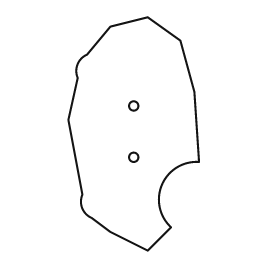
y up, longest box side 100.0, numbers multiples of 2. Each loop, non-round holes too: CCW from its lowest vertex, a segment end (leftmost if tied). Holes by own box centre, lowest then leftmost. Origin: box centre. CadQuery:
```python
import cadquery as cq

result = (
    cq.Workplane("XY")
    .moveTo(6.0, -50.0)
    .lineTo(16.0, -40.0)
    .threePointArc((12.0, -22.0), (28.0, -12.0))
    .lineTo(26.0, 18.0)
    .lineTo(20.0, 40.0)
    .lineTo(6.0, 50.0)
    .lineTo(-10.0, 46.0)
    .lineTo(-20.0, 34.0)
    .threePointArc((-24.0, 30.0), (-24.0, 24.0))
    .lineTo(-28.0, 6.0)
    .lineTo(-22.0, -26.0)
    .threePointArc((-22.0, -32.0), (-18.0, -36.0))
    .lineTo(-10.0, -42.0)
    .close()
    .moveTo(0.0, -10.0)
    .circle(2.0)
    .moveTo(0.0, 12.0)
    .circle(2.0)
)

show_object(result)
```